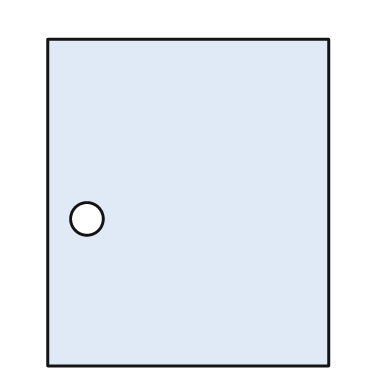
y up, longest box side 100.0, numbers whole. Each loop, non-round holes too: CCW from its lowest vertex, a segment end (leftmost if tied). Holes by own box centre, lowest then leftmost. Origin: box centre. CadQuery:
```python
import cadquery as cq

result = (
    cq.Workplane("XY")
    .moveTo(-43.0, -50.0)
    .lineTo(43.0, -50.0)
    .lineTo(43.0, 50.0)
    .lineTo(-43.0, 50.0)
    .close()
    .moveTo(-31.0, -5.0)
    .circle(5.0)
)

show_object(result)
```